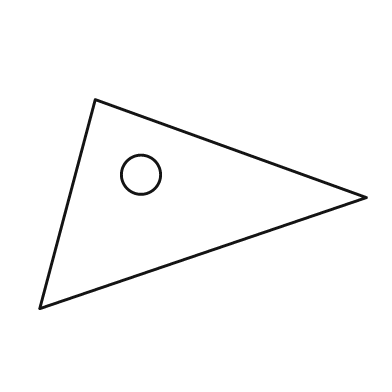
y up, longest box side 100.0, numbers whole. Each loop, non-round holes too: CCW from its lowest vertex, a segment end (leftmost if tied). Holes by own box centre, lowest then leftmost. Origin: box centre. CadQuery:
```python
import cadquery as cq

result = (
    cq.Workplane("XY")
    .moveTo(-50.0, -32.0)
    .lineTo(50.0, 2.0)
    .lineTo(-33.0, 32.0)
    .close()
    .moveTo(-19.0, 9.0)
    .circle(6.0)
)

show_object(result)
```